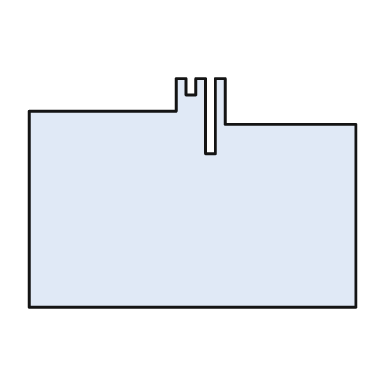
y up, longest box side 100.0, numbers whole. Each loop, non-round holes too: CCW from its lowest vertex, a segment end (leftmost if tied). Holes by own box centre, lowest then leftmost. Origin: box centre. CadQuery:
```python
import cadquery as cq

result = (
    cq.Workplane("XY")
    .moveTo(-50.0, -35.0)
    .lineTo(50.0, -35.0)
    .lineTo(50.0, 21.0)
    .lineTo(10.0, 21.0)
    .lineTo(10.0, 35.0)
    .lineTo(7.0, 35.0)
    .lineTo(7.0, 12.0)
    .lineTo(4.0, 12.0)
    .lineTo(4.0, 35.0)
    .lineTo(1.0, 35.0)
    .lineTo(1.0, 30.0)
    .lineTo(-2.0, 30.0)
    .lineTo(-2.0, 35.0)
    .lineTo(-5.0, 35.0)
    .lineTo(-5.0, 25.0)
    .lineTo(-50.0, 25.0)
    .close()
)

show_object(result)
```